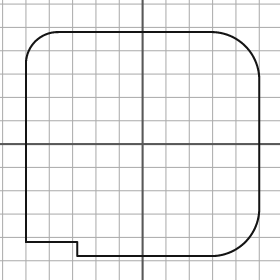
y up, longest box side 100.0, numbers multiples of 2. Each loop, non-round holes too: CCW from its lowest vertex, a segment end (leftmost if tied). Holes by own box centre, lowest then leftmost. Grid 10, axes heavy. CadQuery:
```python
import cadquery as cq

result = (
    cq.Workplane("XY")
    .moveTo(-28.0, -48.0)
    .lineTo(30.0, -48.0)
    .threePointArc((44.0, -42.0), (50.0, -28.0))
    .lineTo(50.0, 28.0)
    .threePointArc((44.0, 42.0), (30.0, 48.0))
    .lineTo(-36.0, 48.0)
    .threePointArc((-46.0, 44.0), (-50.0, 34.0))
    .lineTo(-50.0, -42.0)
    .lineTo(-28.0, -42.0)
    .close()
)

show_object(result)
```